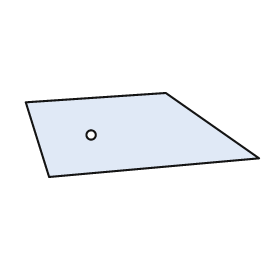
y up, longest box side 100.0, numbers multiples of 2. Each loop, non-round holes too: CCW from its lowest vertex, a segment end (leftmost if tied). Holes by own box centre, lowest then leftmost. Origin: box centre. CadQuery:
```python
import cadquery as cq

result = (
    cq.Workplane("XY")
    .moveTo(-40.0, -18.0)
    .lineTo(50.0, -10.0)
    .lineTo(10.0, 18.0)
    .lineTo(-50.0, 14.0)
    .close()
    .moveTo(-22.0, 0.0)
    .circle(2.0)
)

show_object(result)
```